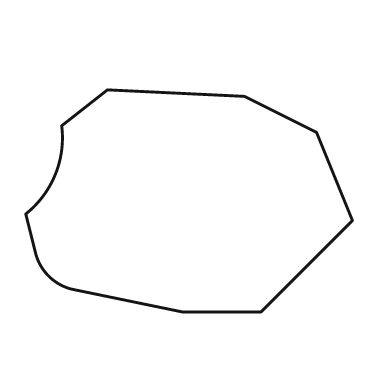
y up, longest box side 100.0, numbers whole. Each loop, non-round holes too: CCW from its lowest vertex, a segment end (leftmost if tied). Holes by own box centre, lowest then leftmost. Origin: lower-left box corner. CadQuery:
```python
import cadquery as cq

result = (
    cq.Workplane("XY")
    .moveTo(48.0, 0.0)
    .lineTo(72.0, 0.0)
    .lineTo(100.0, 28.0)
    .lineTo(89.0, 55.0)
    .lineTo(67.0, 66.0)
    .lineTo(25.0, 68.0)
    .lineTo(11.0, 57.0)
    .threePointArc((9.0, 42.0), (0.0, 30.0))
    .lineTo(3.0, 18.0)
    .threePointArc((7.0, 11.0), (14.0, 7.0))
    .close()
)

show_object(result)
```